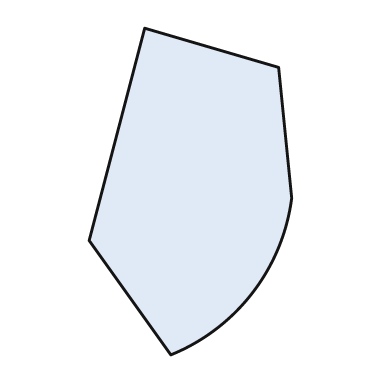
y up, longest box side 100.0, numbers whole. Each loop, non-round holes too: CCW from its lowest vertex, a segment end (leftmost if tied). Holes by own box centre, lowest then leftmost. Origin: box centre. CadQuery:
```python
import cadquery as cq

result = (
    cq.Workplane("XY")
    .moveTo(-6.0, -50.0)
    .threePointArc((19.0, -31.0), (31.0, -2.0))
    .lineTo(27.0, 38.0)
    .lineTo(-14.0, 50.0)
    .lineTo(-31.0, -15.0)
    .close()
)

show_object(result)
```